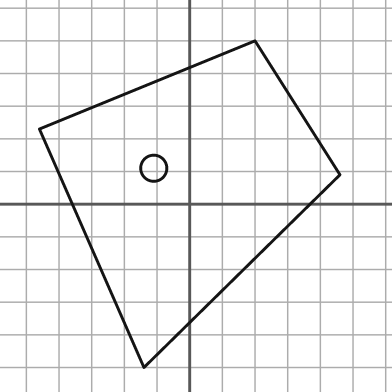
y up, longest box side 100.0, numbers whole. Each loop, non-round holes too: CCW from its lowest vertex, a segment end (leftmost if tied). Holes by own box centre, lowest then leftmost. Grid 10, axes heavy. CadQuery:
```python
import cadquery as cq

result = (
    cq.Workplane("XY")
    .moveTo(-14.0, -50.0)
    .lineTo(46.0, 9.0)
    .lineTo(20.0, 50.0)
    .lineTo(-46.0, 23.0)
    .close()
    .moveTo(-11.0, 11.0)
    .circle(4.0)
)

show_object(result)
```